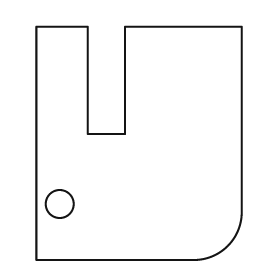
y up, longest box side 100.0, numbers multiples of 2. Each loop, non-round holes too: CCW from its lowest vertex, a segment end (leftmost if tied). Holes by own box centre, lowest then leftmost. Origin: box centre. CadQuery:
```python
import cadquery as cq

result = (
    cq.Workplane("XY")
    .moveTo(-44.0, -50.0)
    .lineTo(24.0, -50.0)
    .threePointArc((38.0, -44.0), (44.0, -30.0))
    .lineTo(44.0, 50.0)
    .lineTo(-6.0, 50.0)
    .lineTo(-6.0, 4.0)
    .lineTo(-22.0, 4.0)
    .lineTo(-22.0, 50.0)
    .lineTo(-44.0, 50.0)
    .close()
    .moveTo(-34.0, -26.0)
    .circle(6.0)
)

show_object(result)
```